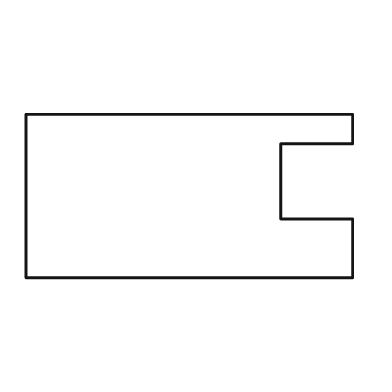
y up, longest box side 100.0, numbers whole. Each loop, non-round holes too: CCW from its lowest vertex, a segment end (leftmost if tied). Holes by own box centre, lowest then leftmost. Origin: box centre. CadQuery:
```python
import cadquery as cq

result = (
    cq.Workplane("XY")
    .moveTo(-50.0, -25.0)
    .lineTo(50.0, -25.0)
    .lineTo(50.0, -7.0)
    .lineTo(28.0, -7.0)
    .lineTo(28.0, 16.0)
    .lineTo(50.0, 16.0)
    .lineTo(50.0, 25.0)
    .lineTo(-50.0, 25.0)
    .close()
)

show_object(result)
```